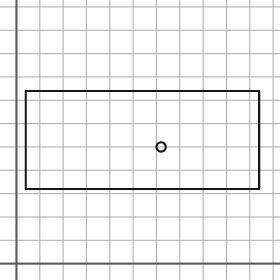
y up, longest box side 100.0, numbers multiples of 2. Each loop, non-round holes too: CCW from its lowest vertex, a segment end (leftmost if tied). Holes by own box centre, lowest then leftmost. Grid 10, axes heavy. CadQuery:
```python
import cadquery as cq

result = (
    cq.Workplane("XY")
    .moveTo(4.0, 32.0)
    .lineTo(104.0, 32.0)
    .lineTo(104.0, 74.0)
    .lineTo(4.0, 74.0)
    .close()
    .moveTo(62.0, 50.0)
    .circle(2.0)
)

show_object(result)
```